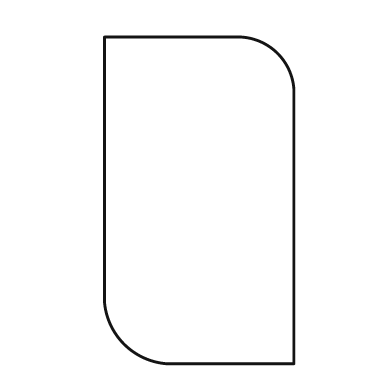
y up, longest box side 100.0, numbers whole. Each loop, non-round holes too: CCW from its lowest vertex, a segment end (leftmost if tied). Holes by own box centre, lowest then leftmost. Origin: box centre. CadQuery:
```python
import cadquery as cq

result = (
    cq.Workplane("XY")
    .moveTo(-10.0, -50.0)
    .lineTo(29.0, -50.0)
    .lineTo(29.0, 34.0)
    .threePointArc((24.0, 45.0), (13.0, 50.0))
    .lineTo(-29.0, 50.0)
    .lineTo(-29.0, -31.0)
    .threePointArc((-23.0, -44.0), (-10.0, -50.0))
    .close()
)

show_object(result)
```